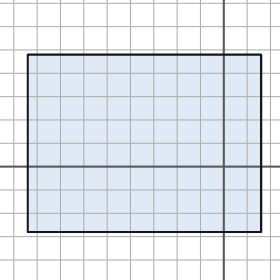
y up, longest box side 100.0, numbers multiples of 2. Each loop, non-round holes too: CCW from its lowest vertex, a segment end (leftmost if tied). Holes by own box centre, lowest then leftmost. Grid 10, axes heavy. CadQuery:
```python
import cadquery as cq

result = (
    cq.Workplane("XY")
    .moveTo(-84.0, -28.0)
    .lineTo(16.0, -28.0)
    .lineTo(16.0, 48.0)
    .lineTo(-84.0, 48.0)
    .close()
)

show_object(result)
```